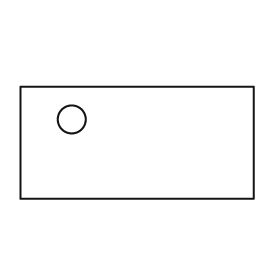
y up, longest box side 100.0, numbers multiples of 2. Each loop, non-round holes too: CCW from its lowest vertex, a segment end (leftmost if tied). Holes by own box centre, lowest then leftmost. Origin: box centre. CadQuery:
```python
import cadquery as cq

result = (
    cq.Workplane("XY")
    .moveTo(-50.0, -24.0)
    .lineTo(50.0, -24.0)
    .lineTo(50.0, 24.0)
    .lineTo(-50.0, 24.0)
    .close()
    .moveTo(-28.0, 10.0)
    .circle(6.0)
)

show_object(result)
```